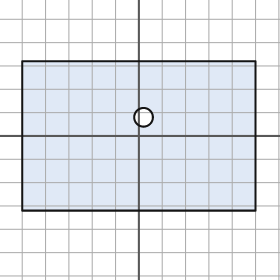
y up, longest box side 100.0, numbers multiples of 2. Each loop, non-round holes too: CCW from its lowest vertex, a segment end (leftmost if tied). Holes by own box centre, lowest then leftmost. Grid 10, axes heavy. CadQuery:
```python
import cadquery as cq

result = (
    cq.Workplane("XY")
    .moveTo(-50.0, -32.0)
    .lineTo(50.0, -32.0)
    .lineTo(50.0, 32.0)
    .lineTo(-50.0, 32.0)
    .close()
    .moveTo(2.0, 8.0)
    .circle(4.0)
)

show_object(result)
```